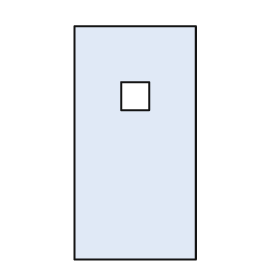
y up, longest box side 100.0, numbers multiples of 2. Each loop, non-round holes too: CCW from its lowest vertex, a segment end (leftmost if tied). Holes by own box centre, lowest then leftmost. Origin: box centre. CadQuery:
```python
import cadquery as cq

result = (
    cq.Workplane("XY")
    .moveTo(-26.0, -50.0)
    .lineTo(26.0, -50.0)
    .lineTo(26.0, 50.0)
    .lineTo(-26.0, 50.0)
    .close()
    .moveTo(-6.0, 14.0)
    .lineTo(6.0, 14.0)
    .lineTo(6.0, 26.0)
    .lineTo(-6.0, 26.0)
    .close()
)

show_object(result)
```